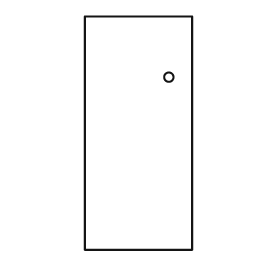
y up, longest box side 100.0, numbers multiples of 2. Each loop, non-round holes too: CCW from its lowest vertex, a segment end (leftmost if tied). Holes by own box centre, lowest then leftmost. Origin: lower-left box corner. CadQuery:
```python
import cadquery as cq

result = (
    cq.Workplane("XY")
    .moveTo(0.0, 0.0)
    .lineTo(46.0, 0.0)
    .lineTo(46.0, 100.0)
    .lineTo(0.0, 100.0)
    .close()
    .moveTo(36.0, 74.0)
    .circle(2.0)
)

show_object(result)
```